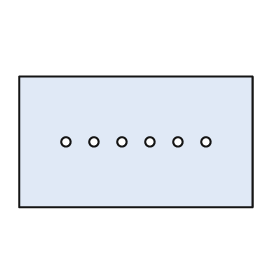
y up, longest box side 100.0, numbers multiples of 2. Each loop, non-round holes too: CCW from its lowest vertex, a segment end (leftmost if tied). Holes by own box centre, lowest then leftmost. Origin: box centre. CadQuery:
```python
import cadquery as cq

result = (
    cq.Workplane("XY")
    .moveTo(-50.0, -28.0)
    .lineTo(50.0, -28.0)
    .lineTo(50.0, 28.0)
    .lineTo(-50.0, 28.0)
    .close()
    .moveTo(-30.0, 0.0)
    .circle(2.0)
    .moveTo(-18.0, 0.0)
    .circle(2.0)
    .moveTo(-6.0, 0.0)
    .circle(2.0)
    .moveTo(6.0, 0.0)
    .circle(2.0)
    .moveTo(18.0, 0.0)
    .circle(2.0)
    .moveTo(30.0, 0.0)
    .circle(2.0)
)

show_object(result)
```